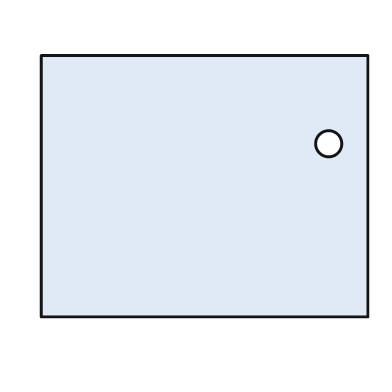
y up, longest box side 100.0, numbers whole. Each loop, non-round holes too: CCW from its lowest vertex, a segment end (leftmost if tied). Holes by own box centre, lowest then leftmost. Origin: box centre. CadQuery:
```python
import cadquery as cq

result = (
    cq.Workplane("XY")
    .moveTo(-50.0, -40.0)
    .lineTo(50.0, -40.0)
    .lineTo(50.0, 40.0)
    .lineTo(-50.0, 40.0)
    .close()
    .moveTo(38.0, 13.0)
    .circle(4.0)
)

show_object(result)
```